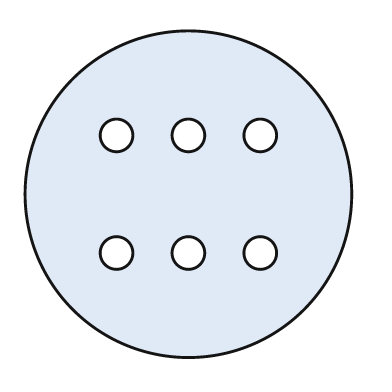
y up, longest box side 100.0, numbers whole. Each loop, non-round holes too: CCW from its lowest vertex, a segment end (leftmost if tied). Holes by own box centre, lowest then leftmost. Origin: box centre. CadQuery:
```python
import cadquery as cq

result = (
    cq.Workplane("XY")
    .moveTo(0.0, 0.0)
    .circle(50.0)
    .moveTo(-22.0, -18.0)
    .circle(5.0)
    .moveTo(0.0, -18.0)
    .circle(5.0)
    .moveTo(22.0, -18.0)
    .circle(5.0)
    .moveTo(-22.0, 18.0)
    .circle(5.0)
    .moveTo(0.0, 18.0)
    .circle(5.0)
    .moveTo(22.0, 18.0)
    .circle(5.0)
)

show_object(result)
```